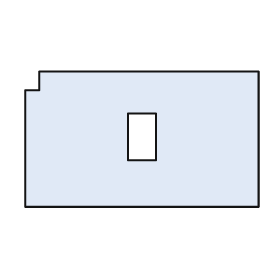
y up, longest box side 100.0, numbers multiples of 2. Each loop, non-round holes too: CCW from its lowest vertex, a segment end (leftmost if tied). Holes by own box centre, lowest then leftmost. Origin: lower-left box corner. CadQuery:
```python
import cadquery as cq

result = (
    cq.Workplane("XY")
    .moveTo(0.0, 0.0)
    .lineTo(100.0, 0.0)
    .lineTo(100.0, 58.0)
    .lineTo(6.0, 58.0)
    .lineTo(6.0, 50.0)
    .lineTo(0.0, 50.0)
    .close()
    .moveTo(44.0, 20.0)
    .lineTo(56.0, 20.0)
    .lineTo(56.0, 40.0)
    .lineTo(44.0, 40.0)
    .close()
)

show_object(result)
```